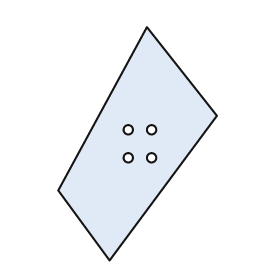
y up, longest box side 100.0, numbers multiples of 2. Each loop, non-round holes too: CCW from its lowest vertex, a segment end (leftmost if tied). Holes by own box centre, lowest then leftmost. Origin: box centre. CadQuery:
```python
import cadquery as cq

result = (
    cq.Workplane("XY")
    .moveTo(-12.0, -50.0)
    .lineTo(34.0, 12.0)
    .lineTo(4.0, 50.0)
    .lineTo(-34.0, -20.0)
    .close()
    .moveTo(-4.0, -6.0)
    .circle(2.0)
    .moveTo(6.0, -6.0)
    .circle(2.0)
    .moveTo(-4.0, 6.0)
    .circle(2.0)
    .moveTo(6.0, 6.0)
    .circle(2.0)
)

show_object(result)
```